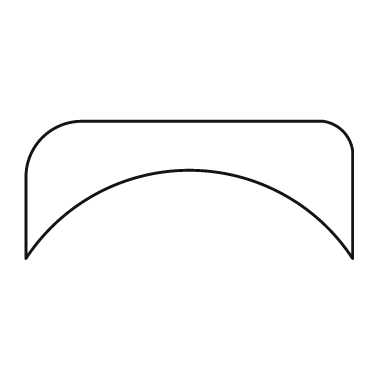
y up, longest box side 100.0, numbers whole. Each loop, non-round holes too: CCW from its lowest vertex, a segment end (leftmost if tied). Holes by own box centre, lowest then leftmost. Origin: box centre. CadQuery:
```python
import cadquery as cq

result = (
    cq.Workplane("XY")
    .moveTo(-50.0, -21.0)
    .threePointArc((0.0, 6.0), (50.0, -21.0))
    .lineTo(50.0, 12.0)
    .threePointArc((47.0, 18.0), (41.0, 21.0))
    .lineTo(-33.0, 21.0)
    .threePointArc((-45.0, 16.0), (-50.0, 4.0))
    .close()
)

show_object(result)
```